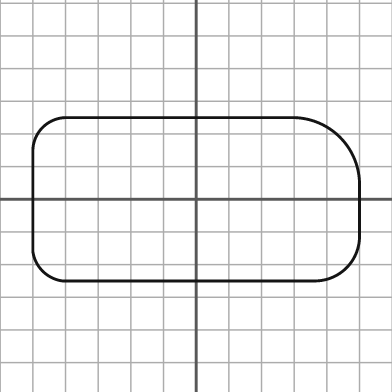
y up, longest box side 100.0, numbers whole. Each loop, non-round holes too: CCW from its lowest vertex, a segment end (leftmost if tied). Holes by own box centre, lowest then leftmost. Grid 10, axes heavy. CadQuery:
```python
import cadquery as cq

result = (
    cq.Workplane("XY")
    .moveTo(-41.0, -25.0)
    .lineTo(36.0, -25.0)
    .threePointArc((46.0, -21.0), (50.0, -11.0))
    .lineTo(50.0, 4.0)
    .threePointArc((44.0, 19.0), (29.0, 25.0))
    .lineTo(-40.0, 25.0)
    .threePointArc((-47.0, 22.0), (-50.0, 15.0))
    .lineTo(-50.0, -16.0)
    .threePointArc((-47.0, -22.0), (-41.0, -25.0))
    .close()
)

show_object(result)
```